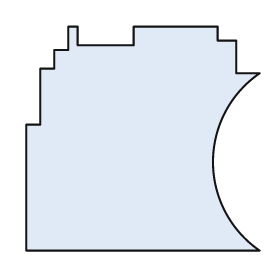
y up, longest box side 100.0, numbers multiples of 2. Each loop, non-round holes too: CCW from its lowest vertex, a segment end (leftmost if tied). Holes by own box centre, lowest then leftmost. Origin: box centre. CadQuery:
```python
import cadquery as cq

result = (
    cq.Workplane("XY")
    .moveTo(-50.0, -48.0)
    .lineTo(50.0, -48.0)
    .threePointArc((30.0, -10.0), (50.0, 28.0))
    .lineTo(40.0, 28.0)
    .lineTo(40.0, 42.0)
    .lineTo(32.0, 42.0)
    .lineTo(32.0, 48.0)
    .lineTo(-4.0, 48.0)
    .lineTo(-4.0, 40.0)
    .lineTo(-28.0, 40.0)
    .lineTo(-28.0, 48.0)
    .lineTo(-32.0, 48.0)
    .lineTo(-32.0, 38.0)
    .lineTo(-38.0, 38.0)
    .lineTo(-38.0, 30.0)
    .lineTo(-44.0, 30.0)
    .lineTo(-44.0, 6.0)
    .lineTo(-50.0, 6.0)
    .close()
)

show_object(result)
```